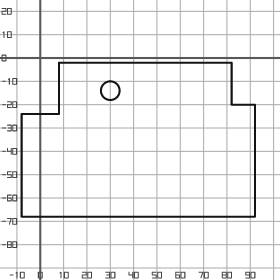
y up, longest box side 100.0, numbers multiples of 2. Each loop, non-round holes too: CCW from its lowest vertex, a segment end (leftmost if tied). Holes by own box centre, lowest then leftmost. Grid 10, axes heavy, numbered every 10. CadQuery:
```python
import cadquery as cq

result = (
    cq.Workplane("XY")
    .moveTo(-8.0, -68.0)
    .lineTo(92.0, -68.0)
    .lineTo(92.0, -20.0)
    .lineTo(82.0, -20.0)
    .lineTo(82.0, -2.0)
    .lineTo(8.0, -2.0)
    .lineTo(8.0, -24.0)
    .lineTo(-8.0, -24.0)
    .close()
    .moveTo(30.0, -14.0)
    .circle(4.0)
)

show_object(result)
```